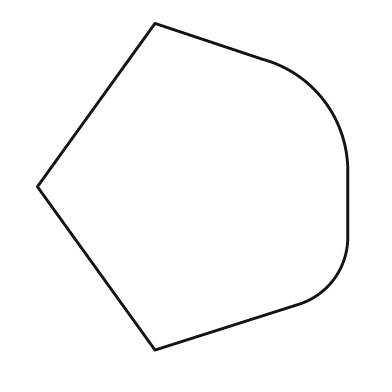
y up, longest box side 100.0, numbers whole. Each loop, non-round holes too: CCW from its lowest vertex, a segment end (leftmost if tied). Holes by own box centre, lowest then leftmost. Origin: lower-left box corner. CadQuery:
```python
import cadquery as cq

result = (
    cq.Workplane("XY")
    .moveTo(36.0, 0.0)
    .lineTo(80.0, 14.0)
    .threePointArc((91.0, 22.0), (95.0, 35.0))
    .lineTo(95.0, 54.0)
    .threePointArc((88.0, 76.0), (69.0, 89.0))
    .lineTo(36.0, 100.0)
    .lineTo(0.0, 50.0)
    .close()
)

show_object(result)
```